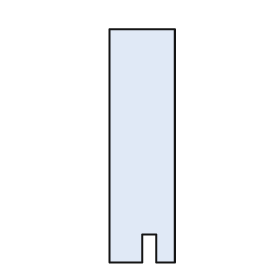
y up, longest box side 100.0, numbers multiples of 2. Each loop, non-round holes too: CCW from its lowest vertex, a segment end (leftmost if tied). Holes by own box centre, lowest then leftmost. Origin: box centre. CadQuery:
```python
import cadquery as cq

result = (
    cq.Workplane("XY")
    .moveTo(-14.0, -50.0)
    .lineTo(0.0, -50.0)
    .lineTo(0.0, -38.0)
    .lineTo(6.0, -38.0)
    .lineTo(6.0, -50.0)
    .lineTo(14.0, -50.0)
    .lineTo(14.0, 50.0)
    .lineTo(-14.0, 50.0)
    .close()
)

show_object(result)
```